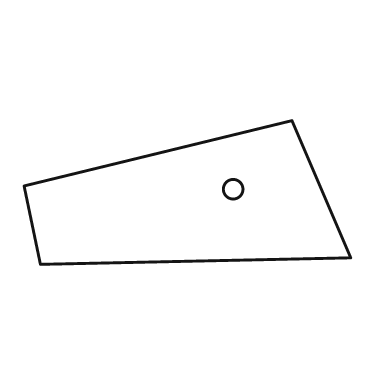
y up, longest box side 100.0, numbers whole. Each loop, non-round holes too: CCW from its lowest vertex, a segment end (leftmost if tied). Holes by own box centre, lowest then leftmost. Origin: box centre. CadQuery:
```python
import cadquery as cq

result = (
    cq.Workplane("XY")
    .moveTo(-45.0, -22.0)
    .lineTo(50.0, -20.0)
    .lineTo(32.0, 22.0)
    .lineTo(-50.0, 2.0)
    .close()
    .moveTo(14.0, 1.0)
    .circle(3.0)
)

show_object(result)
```